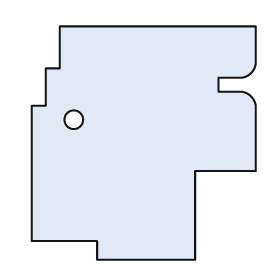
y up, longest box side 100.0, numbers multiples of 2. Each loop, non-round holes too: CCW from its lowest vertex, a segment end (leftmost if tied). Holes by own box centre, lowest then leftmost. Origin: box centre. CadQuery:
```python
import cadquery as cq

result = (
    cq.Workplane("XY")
    .moveTo(-20.0, -50.0)
    .lineTo(22.0, -50.0)
    .lineTo(22.0, -12.0)
    .lineTo(48.0, -12.0)
    .lineTo(48.0, 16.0)
    .threePointArc((46.0, 20.0), (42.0, 22.0))
    .lineTo(32.0, 22.0)
    .lineTo(32.0, 28.0)
    .lineTo(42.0, 28.0)
    .threePointArc((46.0, 30.0), (48.0, 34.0))
    .lineTo(48.0, 50.0)
    .lineTo(-36.0, 50.0)
    .lineTo(-36.0, 32.0)
    .lineTo(-42.0, 32.0)
    .lineTo(-42.0, 16.0)
    .lineTo(-48.0, 16.0)
    .lineTo(-48.0, -42.0)
    .lineTo(-20.0, -42.0)
    .close()
    .moveTo(-30.0, 10.0)
    .circle(4.0)
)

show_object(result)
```